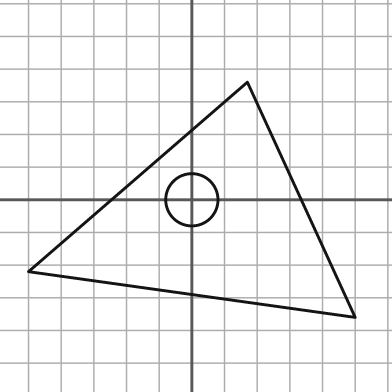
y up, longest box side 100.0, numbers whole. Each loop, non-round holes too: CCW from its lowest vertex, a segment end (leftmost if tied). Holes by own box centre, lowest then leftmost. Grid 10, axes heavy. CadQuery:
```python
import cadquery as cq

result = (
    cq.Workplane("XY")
    .moveTo(50.0, -36.0)
    .lineTo(17.0, 36.0)
    .lineTo(-50.0, -22.0)
    .close()
    .moveTo(0.0, 0.0)
    .circle(8.0)
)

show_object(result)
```